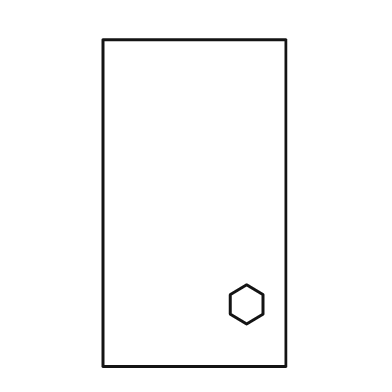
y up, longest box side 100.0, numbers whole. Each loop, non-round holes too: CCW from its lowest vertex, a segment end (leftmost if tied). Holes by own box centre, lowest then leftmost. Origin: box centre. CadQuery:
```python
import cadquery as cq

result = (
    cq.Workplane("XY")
    .moveTo(-28.0, -50.0)
    .lineTo(28.0, -50.0)
    .lineTo(28.0, 50.0)
    .lineTo(-28.0, 50.0)
    .close()
    .moveTo(16.0, -37.0)
    .lineTo(21.0, -34.0)
    .lineTo(21.0, -28.0)
    .lineTo(16.0, -25.0)
    .lineTo(11.0, -28.0)
    .lineTo(11.0, -34.0)
    .close()
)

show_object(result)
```